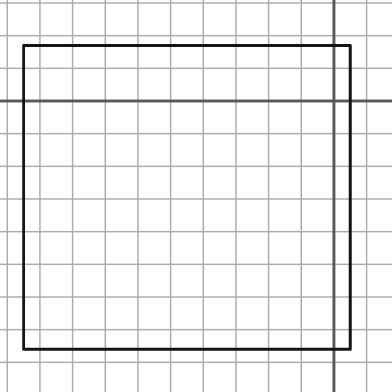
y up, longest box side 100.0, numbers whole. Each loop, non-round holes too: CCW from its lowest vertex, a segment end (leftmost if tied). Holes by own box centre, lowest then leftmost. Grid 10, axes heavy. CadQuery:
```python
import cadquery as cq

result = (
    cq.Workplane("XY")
    .moveTo(-95.0, -76.0)
    .lineTo(5.0, -76.0)
    .lineTo(5.0, 17.0)
    .lineTo(-95.0, 17.0)
    .close()
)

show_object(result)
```